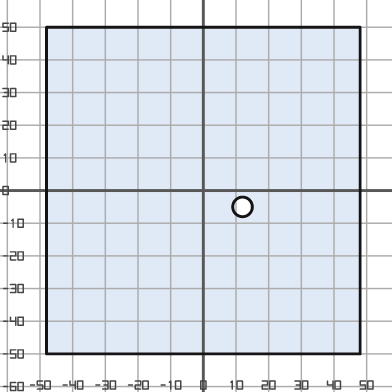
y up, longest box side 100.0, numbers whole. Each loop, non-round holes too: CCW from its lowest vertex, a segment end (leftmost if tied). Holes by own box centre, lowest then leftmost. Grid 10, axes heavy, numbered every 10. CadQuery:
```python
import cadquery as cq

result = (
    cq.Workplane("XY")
    .moveTo(-48.0, -50.0)
    .lineTo(48.0, -50.0)
    .lineTo(48.0, 50.0)
    .lineTo(-48.0, 50.0)
    .close()
    .moveTo(12.0, -5.0)
    .circle(3.0)
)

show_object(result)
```